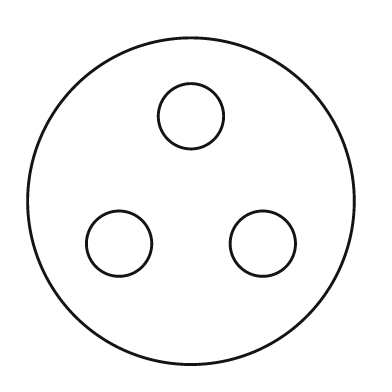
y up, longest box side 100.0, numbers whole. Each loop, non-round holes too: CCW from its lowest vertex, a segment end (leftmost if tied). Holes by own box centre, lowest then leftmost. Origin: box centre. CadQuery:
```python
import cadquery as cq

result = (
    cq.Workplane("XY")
    .moveTo(0.0, 0.0)
    .circle(50.0)
    .moveTo(-22.0, -13.0)
    .circle(10.0)
    .moveTo(22.0, -13.0)
    .circle(10.0)
    .moveTo(0.0, 26.0)
    .circle(10.0)
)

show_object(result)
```